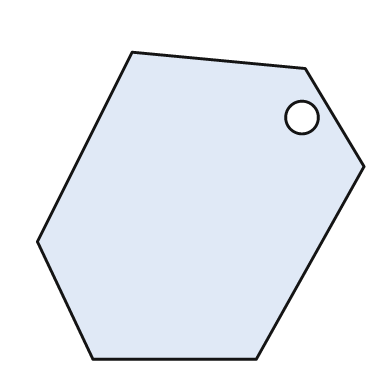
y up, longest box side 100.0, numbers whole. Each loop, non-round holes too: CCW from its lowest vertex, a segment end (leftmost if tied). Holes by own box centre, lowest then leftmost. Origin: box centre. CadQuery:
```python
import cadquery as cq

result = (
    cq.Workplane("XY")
    .moveTo(-33.0, -47.0)
    .lineTo(17.0, -47.0)
    .lineTo(50.0, 12.0)
    .lineTo(32.0, 42.0)
    .lineTo(-21.0, 47.0)
    .lineTo(-50.0, -11.0)
    .close()
    .moveTo(31.0, 27.0)
    .circle(5.0)
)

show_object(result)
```